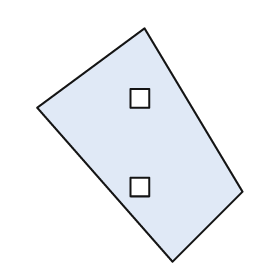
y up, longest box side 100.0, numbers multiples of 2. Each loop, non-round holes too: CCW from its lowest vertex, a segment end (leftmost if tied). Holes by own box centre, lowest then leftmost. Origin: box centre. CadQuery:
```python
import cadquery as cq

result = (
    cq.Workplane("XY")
    .moveTo(14.0, -50.0)
    .lineTo(44.0, -20.0)
    .lineTo(2.0, 50.0)
    .lineTo(-44.0, 16.0)
    .close()
    .moveTo(-4.0, -22.0)
    .lineTo(4.0, -22.0)
    .lineTo(4.0, -14.0)
    .lineTo(-4.0, -14.0)
    .close()
    .moveTo(-4.0, 16.0)
    .lineTo(4.0, 16.0)
    .lineTo(4.0, 24.0)
    .lineTo(-4.0, 24.0)
    .close()
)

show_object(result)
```